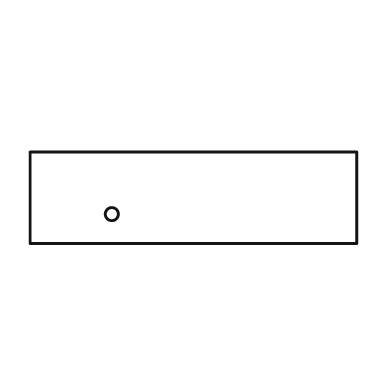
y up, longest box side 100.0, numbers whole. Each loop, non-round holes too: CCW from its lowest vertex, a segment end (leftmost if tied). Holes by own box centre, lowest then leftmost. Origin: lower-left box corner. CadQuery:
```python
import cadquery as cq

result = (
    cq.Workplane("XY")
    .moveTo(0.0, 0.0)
    .lineTo(100.0, 0.0)
    .lineTo(100.0, 28.0)
    .lineTo(0.0, 28.0)
    .close()
    .moveTo(25.0, 9.0)
    .circle(2.0)
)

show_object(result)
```